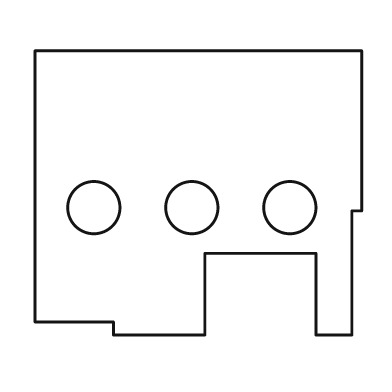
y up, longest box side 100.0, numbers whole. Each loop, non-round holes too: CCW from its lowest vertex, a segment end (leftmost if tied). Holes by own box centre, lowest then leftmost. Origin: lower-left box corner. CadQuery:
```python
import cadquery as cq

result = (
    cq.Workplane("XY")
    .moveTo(24.0, 0.0)
    .lineTo(52.0, 0.0)
    .lineTo(52.0, 25.0)
    .lineTo(86.0, 25.0)
    .lineTo(86.0, 0.0)
    .lineTo(97.0, 0.0)
    .lineTo(97.0, 38.0)
    .lineTo(100.0, 38.0)
    .lineTo(100.0, 87.0)
    .lineTo(0.0, 87.0)
    .lineTo(0.0, 4.0)
    .lineTo(24.0, 4.0)
    .close()
    .moveTo(18.0, 39.0)
    .circle(8.0)
    .moveTo(48.0, 39.0)
    .circle(8.0)
    .moveTo(78.0, 39.0)
    .circle(8.0)
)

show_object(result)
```